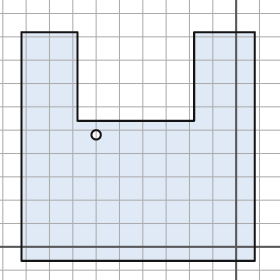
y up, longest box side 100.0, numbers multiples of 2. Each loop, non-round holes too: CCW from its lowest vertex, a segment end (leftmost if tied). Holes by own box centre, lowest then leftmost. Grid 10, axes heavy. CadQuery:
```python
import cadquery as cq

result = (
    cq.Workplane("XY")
    .moveTo(-92.0, -6.0)
    .lineTo(8.0, -6.0)
    .lineTo(8.0, 92.0)
    .lineTo(-18.0, 92.0)
    .lineTo(-18.0, 54.0)
    .lineTo(-68.0, 54.0)
    .lineTo(-68.0, 92.0)
    .lineTo(-92.0, 92.0)
    .close()
    .moveTo(-60.0, 48.0)
    .circle(2.0)
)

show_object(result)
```